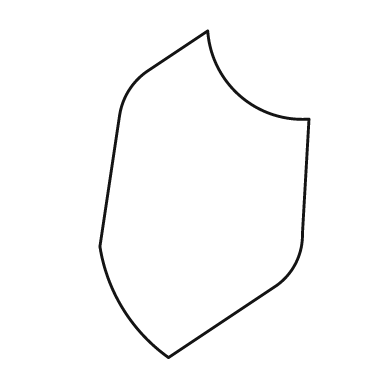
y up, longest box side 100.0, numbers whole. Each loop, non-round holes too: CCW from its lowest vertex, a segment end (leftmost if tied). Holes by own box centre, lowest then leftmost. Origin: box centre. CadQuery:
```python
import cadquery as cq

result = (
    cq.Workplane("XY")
    .moveTo(-11.0, -50.0)
    .lineTo(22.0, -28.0)
    .threePointArc((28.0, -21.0), (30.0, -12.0))
    .lineTo(32.0, 23.0)
    .threePointArc((11.0, 30.0), (1.0, 50.0))
    .lineTo(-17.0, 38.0)
    .threePointArc((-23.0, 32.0), (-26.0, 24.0))
    .lineTo(-32.0, -16.0)
    .threePointArc((-25.0, -35.0), (-11.0, -50.0))
    .close()
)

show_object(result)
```